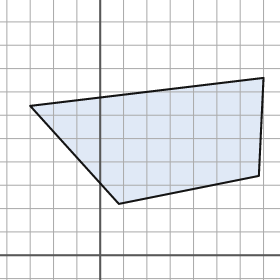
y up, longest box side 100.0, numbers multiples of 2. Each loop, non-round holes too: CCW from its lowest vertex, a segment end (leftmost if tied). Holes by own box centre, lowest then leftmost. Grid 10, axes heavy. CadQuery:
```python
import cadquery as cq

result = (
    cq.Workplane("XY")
    .moveTo(8.0, 22.0)
    .lineTo(68.0, 34.0)
    .lineTo(70.0, 76.0)
    .lineTo(-30.0, 64.0)
    .close()
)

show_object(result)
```